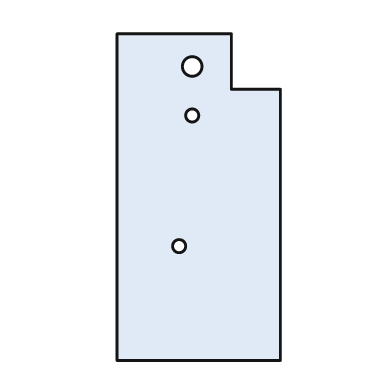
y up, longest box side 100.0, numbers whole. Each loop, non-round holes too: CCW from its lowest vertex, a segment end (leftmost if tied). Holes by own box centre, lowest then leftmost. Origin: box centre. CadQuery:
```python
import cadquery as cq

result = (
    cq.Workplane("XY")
    .moveTo(-25.0, -50.0)
    .lineTo(25.0, -50.0)
    .lineTo(25.0, 33.0)
    .lineTo(10.0, 33.0)
    .lineTo(10.0, 50.0)
    .lineTo(-25.0, 50.0)
    .close()
    .moveTo(-6.0, -15.0)
    .circle(2.0)
    .moveTo(-2.0, 25.0)
    .circle(2.0)
    .moveTo(-2.0, 40.0)
    .circle(3.0)
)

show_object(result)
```